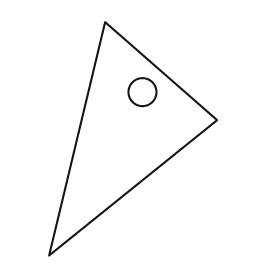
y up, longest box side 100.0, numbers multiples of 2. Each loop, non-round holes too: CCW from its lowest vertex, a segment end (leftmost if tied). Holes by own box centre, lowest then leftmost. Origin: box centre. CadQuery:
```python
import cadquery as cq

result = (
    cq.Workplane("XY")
    .moveTo(-36.0, -50.0)
    .lineTo(36.0, 8.0)
    .lineTo(-12.0, 50.0)
    .close()
    .moveTo(4.0, 20.0)
    .circle(6.0)
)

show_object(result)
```